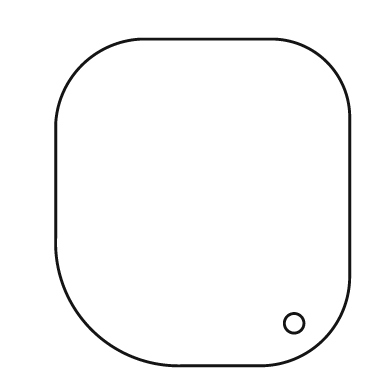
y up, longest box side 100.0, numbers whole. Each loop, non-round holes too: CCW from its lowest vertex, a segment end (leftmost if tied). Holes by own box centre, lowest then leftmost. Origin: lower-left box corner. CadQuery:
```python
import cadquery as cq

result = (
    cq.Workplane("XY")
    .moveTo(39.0, 0.0)
    .lineTo(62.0, 0.0)
    .threePointArc((82.0, 8.0), (90.0, 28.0))
    .lineTo(90.0, 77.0)
    .threePointArc((83.0, 93.0), (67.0, 100.0))
    .lineTo(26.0, 100.0)
    .threePointArc((8.0, 92.0), (0.0, 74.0))
    .lineTo(0.0, 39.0)
    .threePointArc((11.0, 11.0), (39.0, 0.0))
    .close()
    .moveTo(73.0, 13.0)
    .circle(3.0)
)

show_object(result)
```